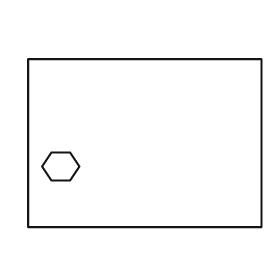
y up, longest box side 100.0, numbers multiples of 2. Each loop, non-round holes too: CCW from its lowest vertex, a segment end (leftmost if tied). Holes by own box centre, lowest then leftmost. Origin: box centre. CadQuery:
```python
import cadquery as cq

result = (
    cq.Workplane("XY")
    .moveTo(-50.0, -36.0)
    .lineTo(50.0, -36.0)
    .lineTo(50.0, 36.0)
    .lineTo(-50.0, 36.0)
    .close()
    .moveTo(-40.0, -16.0)
    .lineTo(-32.0, -16.0)
    .lineTo(-28.0, -10.0)
    .lineTo(-32.0, -4.0)
    .lineTo(-40.0, -4.0)
    .lineTo(-44.0, -10.0)
    .close()
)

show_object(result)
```